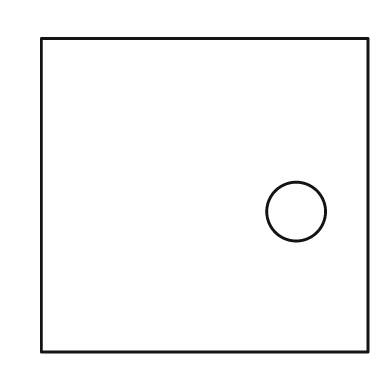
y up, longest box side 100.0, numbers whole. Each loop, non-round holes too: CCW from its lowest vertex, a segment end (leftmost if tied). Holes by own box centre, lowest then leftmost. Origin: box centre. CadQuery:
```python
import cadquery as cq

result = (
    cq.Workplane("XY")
    .moveTo(-50.0, -48.0)
    .lineTo(50.0, -48.0)
    .lineTo(50.0, 48.0)
    .lineTo(-50.0, 48.0)
    .close()
    .moveTo(28.0, -5.0)
    .circle(9.0)
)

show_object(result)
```